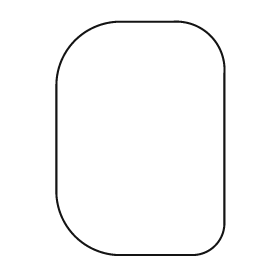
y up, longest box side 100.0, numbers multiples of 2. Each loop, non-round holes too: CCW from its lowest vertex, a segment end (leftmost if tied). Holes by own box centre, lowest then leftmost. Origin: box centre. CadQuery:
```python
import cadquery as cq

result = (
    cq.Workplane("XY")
    .moveTo(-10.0, -50.0)
    .lineTo(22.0, -50.0)
    .threePointArc((32.0, -46.0), (36.0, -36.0))
    .lineTo(36.0, 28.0)
    .threePointArc((30.0, 44.0), (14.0, 50.0))
    .lineTo(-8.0, 50.0)
    .threePointArc((-28.0, 42.0), (-36.0, 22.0))
    .lineTo(-36.0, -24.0)
    .threePointArc((-28.0, -42.0), (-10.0, -50.0))
    .close()
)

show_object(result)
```